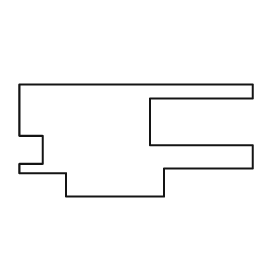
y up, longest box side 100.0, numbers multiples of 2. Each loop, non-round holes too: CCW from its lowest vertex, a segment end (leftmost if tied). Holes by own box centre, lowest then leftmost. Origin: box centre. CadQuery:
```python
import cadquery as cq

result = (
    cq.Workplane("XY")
    .moveTo(-30.0, -24.0)
    .lineTo(12.0, -24.0)
    .lineTo(12.0, -12.0)
    .lineTo(50.0, -12.0)
    .lineTo(50.0, -2.0)
    .lineTo(6.0, -2.0)
    .lineTo(6.0, 18.0)
    .lineTo(50.0, 18.0)
    .lineTo(50.0, 24.0)
    .lineTo(-50.0, 24.0)
    .lineTo(-50.0, 2.0)
    .lineTo(-40.0, 2.0)
    .lineTo(-40.0, -10.0)
    .lineTo(-50.0, -10.0)
    .lineTo(-50.0, -14.0)
    .lineTo(-30.0, -14.0)
    .close()
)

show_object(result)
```